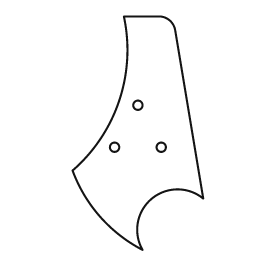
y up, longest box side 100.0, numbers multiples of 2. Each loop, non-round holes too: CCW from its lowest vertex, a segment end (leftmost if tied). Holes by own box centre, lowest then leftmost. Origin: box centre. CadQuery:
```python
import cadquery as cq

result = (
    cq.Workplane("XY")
    .moveTo(2.0, -50.0)
    .threePointArc((6.0, -28.0), (28.0, -28.0))
    .lineTo(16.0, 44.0)
    .threePointArc((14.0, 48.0), (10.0, 50.0))
    .lineTo(-6.0, 50.0)
    .threePointArc((-8.0, 14.0), (-28.0, -16.0))
    .threePointArc((-16.0, -36.0), (2.0, -50.0))
    .close()
    .moveTo(-10.0, -6.0)
    .circle(2.0)
    .moveTo(10.0, -6.0)
    .circle(2.0)
    .moveTo(0.0, 12.0)
    .circle(2.0)
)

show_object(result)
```